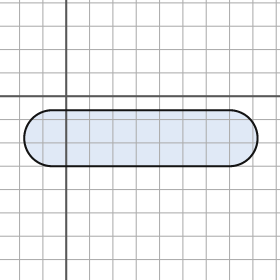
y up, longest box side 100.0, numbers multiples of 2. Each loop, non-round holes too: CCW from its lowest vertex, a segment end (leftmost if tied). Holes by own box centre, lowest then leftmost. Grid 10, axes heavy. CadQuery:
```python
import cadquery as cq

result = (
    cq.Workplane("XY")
    .moveTo(-6.0, -30.0)
    .lineTo(70.0, -30.0)
    .threePointArc((82.0, -18.0), (70.0, -6.0))
    .lineTo(-6.0, -6.0)
    .threePointArc((-18.0, -18.0), (-6.0, -30.0))
    .close()
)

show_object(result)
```